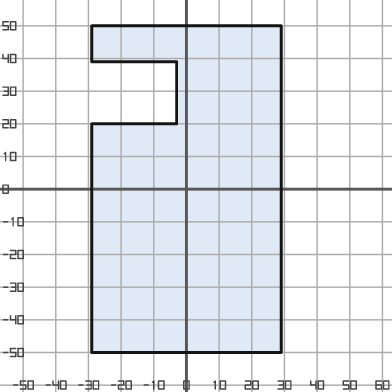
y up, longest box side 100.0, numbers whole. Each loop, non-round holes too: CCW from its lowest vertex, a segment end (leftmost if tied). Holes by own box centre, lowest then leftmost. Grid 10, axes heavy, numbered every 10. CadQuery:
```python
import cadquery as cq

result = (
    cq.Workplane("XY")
    .moveTo(-29.0, -50.0)
    .lineTo(29.0, -50.0)
    .lineTo(29.0, 50.0)
    .lineTo(-29.0, 50.0)
    .lineTo(-29.0, 39.0)
    .lineTo(-3.0, 39.0)
    .lineTo(-3.0, 20.0)
    .lineTo(-29.0, 20.0)
    .close()
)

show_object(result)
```